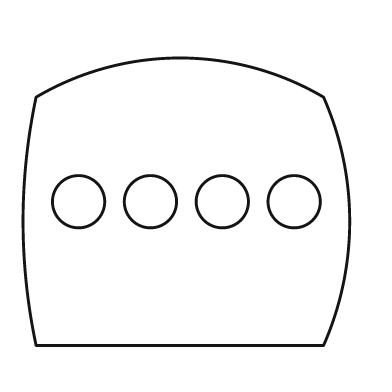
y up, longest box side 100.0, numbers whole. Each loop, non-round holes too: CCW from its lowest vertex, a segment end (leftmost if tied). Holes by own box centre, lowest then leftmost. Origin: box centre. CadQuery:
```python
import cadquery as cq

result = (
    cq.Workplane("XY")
    .moveTo(-46.0, -44.0)
    .lineTo(42.0, -44.0)
    .threePointArc((50.0, -6.0), (42.0, 32.0))
    .threePointArc((-2.0, 44.0), (-46.0, 32.0))
    .threePointArc((-50.0, -6.0), (-46.0, -44.0))
    .close()
    .moveTo(-33.0, 0.0)
    .circle(8.0)
    .moveTo(-11.0, 0.0)
    .circle(8.0)
    .moveTo(11.0, 0.0)
    .circle(8.0)
    .moveTo(33.0, 0.0)
    .circle(8.0)
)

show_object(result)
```